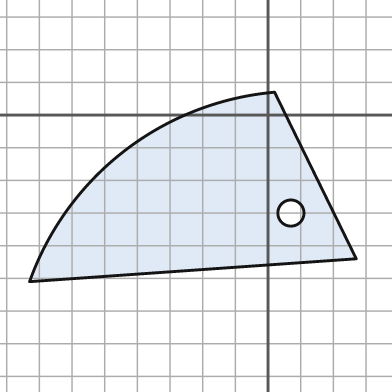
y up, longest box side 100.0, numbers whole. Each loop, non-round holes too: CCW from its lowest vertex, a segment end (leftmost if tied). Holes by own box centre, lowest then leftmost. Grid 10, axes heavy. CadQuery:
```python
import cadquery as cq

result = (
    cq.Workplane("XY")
    .moveTo(-73.0, -51.0)
    .lineTo(27.0, -44.0)
    .lineTo(2.0, 7.0)
    .threePointArc((-44.0, -11.0), (-73.0, -51.0))
    .close()
    .moveTo(7.0, -30.0)
    .circle(4.0)
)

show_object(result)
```